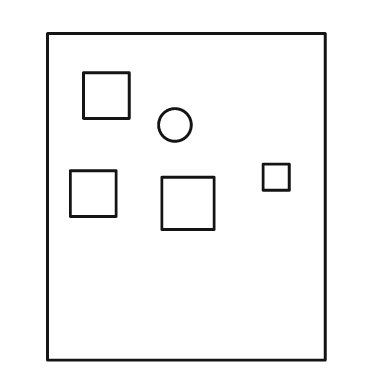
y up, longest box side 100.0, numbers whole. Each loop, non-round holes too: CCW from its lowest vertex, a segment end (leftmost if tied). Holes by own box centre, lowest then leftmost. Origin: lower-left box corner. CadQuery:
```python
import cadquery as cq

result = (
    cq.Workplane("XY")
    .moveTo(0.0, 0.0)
    .lineTo(85.0, 0.0)
    .lineTo(85.0, 100.0)
    .lineTo(0.0, 100.0)
    .close()
    .moveTo(35.0, 40.0)
    .lineTo(51.0, 40.0)
    .lineTo(51.0, 56.0)
    .lineTo(35.0, 56.0)
    .close()
    .moveTo(7.0, 44.0)
    .lineTo(21.0, 44.0)
    .lineTo(21.0, 58.0)
    .lineTo(7.0, 58.0)
    .close()
    .moveTo(66.0, 52.0)
    .lineTo(74.0, 52.0)
    .lineTo(74.0, 60.0)
    .lineTo(66.0, 60.0)
    .close()
    .moveTo(39.0, 72.0)
    .circle(5.0)
    .moveTo(11.0, 74.0)
    .lineTo(25.0, 74.0)
    .lineTo(25.0, 88.0)
    .lineTo(11.0, 88.0)
    .close()
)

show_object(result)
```